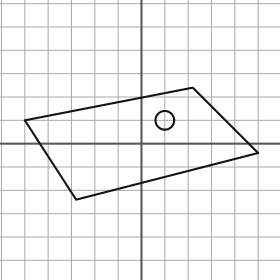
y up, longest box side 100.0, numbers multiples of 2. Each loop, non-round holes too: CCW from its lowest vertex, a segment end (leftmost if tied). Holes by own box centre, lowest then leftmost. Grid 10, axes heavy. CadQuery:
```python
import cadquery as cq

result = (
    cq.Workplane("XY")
    .moveTo(-28.0, -24.0)
    .lineTo(50.0, -4.0)
    .lineTo(22.0, 24.0)
    .lineTo(-50.0, 10.0)
    .close()
    .moveTo(10.0, 10.0)
    .circle(4.0)
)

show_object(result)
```